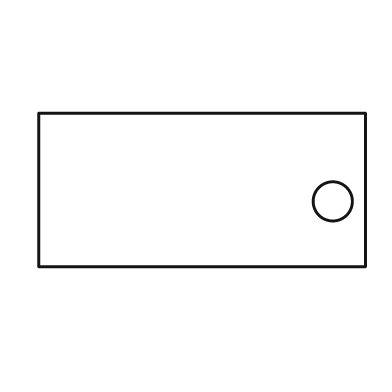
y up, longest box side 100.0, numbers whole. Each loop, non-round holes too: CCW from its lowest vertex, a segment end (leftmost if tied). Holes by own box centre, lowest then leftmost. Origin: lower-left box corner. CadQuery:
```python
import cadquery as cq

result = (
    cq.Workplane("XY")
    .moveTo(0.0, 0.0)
    .lineTo(100.0, 0.0)
    .lineTo(100.0, 47.0)
    .lineTo(0.0, 47.0)
    .close()
    .moveTo(90.0, 20.0)
    .circle(6.0)
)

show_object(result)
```